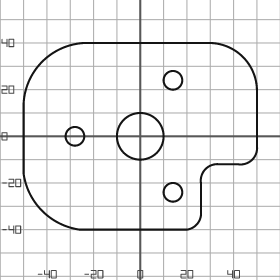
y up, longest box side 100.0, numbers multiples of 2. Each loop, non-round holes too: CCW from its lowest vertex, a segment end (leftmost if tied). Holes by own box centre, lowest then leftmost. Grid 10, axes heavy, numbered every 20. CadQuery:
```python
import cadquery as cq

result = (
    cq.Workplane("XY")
    .moveTo(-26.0, -40.0)
    .lineTo(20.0, -40.0)
    .threePointArc((24.0, -38.0), (26.0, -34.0))
    .lineTo(26.0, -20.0)
    .threePointArc((28.0, -14.0), (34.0, -12.0))
    .lineTo(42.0, -12.0)
    .threePointArc((48.0, -10.0), (50.0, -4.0))
    .lineTo(50.0, 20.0)
    .threePointArc((44.0, 34.0), (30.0, 40.0))
    .lineTo(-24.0, 40.0)
    .threePointArc((-42.0, 32.0), (-50.0, 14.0))
    .lineTo(-50.0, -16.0)
    .threePointArc((-42.0, -32.0), (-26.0, -40.0))
    .close()
    .moveTo(14.0, -24.0)
    .circle(4.0)
    .moveTo(-28.0, 0.0)
    .circle(4.0)
    .moveTo(0.0, 0.0)
    .circle(10.0)
    .moveTo(14.0, 24.0)
    .circle(4.0)
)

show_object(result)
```